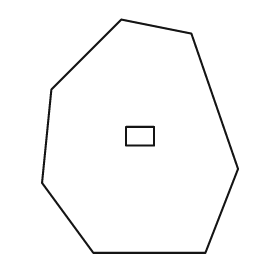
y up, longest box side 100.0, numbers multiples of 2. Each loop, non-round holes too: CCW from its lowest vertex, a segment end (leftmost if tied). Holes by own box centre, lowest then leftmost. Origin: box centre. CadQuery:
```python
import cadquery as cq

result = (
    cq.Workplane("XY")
    .moveTo(-20.0, -50.0)
    .lineTo(28.0, -50.0)
    .lineTo(42.0, -14.0)
    .lineTo(22.0, 44.0)
    .lineTo(-8.0, 50.0)
    .lineTo(-38.0, 20.0)
    .lineTo(-42.0, -20.0)
    .close()
    .moveTo(-6.0, -4.0)
    .lineTo(6.0, -4.0)
    .lineTo(6.0, 4.0)
    .lineTo(-6.0, 4.0)
    .close()
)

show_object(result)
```